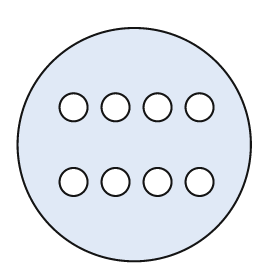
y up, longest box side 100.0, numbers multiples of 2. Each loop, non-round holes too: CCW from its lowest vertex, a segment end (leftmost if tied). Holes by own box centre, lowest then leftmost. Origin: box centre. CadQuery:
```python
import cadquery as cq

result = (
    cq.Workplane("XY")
    .moveTo(0.0, 0.0)
    .circle(50.0)
    .moveTo(-26.0, -16.0)
    .circle(6.0)
    .moveTo(-8.0, -16.0)
    .circle(6.0)
    .moveTo(10.0, -16.0)
    .circle(6.0)
    .moveTo(28.0, -16.0)
    .circle(6.0)
    .moveTo(-26.0, 16.0)
    .circle(6.0)
    .moveTo(-8.0, 16.0)
    .circle(6.0)
    .moveTo(10.0, 16.0)
    .circle(6.0)
    .moveTo(28.0, 16.0)
    .circle(6.0)
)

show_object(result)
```